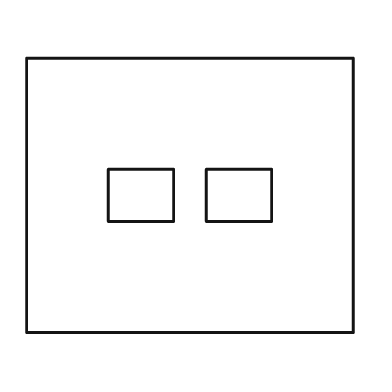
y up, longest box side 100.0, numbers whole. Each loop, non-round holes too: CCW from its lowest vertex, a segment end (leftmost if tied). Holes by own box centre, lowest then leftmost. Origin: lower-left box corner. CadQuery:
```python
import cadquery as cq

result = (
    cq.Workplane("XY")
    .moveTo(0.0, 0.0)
    .lineTo(100.0, 0.0)
    .lineTo(100.0, 84.0)
    .lineTo(0.0, 84.0)
    .close()
    .moveTo(25.0, 34.0)
    .lineTo(45.0, 34.0)
    .lineTo(45.0, 50.0)
    .lineTo(25.0, 50.0)
    .close()
    .moveTo(55.0, 34.0)
    .lineTo(75.0, 34.0)
    .lineTo(75.0, 50.0)
    .lineTo(55.0, 50.0)
    .close()
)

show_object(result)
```